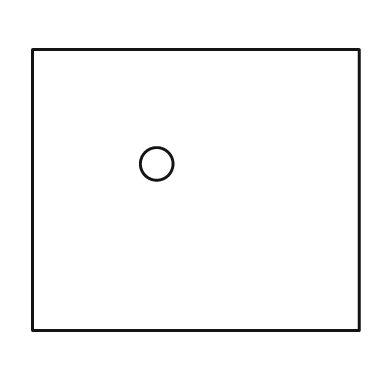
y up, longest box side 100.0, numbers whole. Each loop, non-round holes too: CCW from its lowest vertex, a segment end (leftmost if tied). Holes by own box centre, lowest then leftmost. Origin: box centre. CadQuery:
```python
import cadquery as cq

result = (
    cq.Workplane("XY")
    .moveTo(-50.0, -43.0)
    .lineTo(50.0, -43.0)
    .lineTo(50.0, 43.0)
    .lineTo(-50.0, 43.0)
    .close()
    .moveTo(-12.0, 8.0)
    .circle(5.0)
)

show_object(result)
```